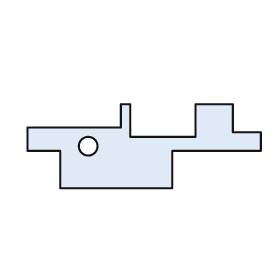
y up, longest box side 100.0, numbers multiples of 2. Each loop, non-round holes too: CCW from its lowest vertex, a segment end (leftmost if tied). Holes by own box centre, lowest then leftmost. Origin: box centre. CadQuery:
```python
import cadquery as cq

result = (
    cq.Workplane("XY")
    .moveTo(-36.0, -18.0)
    .lineTo(12.0, -18.0)
    .lineTo(12.0, -2.0)
    .lineTo(50.0, -2.0)
    .lineTo(50.0, 6.0)
    .lineTo(38.0, 6.0)
    .lineTo(38.0, 18.0)
    .lineTo(22.0, 18.0)
    .lineTo(22.0, 4.0)
    .lineTo(-6.0, 4.0)
    .lineTo(-6.0, 18.0)
    .lineTo(-10.0, 18.0)
    .lineTo(-10.0, 8.0)
    .lineTo(-50.0, 8.0)
    .lineTo(-50.0, -2.0)
    .lineTo(-36.0, -2.0)
    .close()
    .moveTo(-24.0, 0.0)
    .circle(4.0)
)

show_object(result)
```